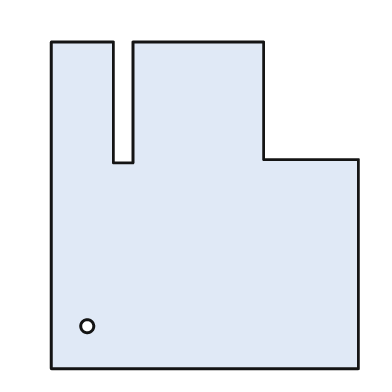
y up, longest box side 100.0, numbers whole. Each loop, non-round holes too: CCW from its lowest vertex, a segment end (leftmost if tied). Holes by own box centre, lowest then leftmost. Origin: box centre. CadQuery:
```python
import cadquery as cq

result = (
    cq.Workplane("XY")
    .moveTo(-47.0, -50.0)
    .lineTo(47.0, -50.0)
    .lineTo(47.0, 14.0)
    .lineTo(18.0, 14.0)
    .lineTo(18.0, 50.0)
    .lineTo(-22.0, 50.0)
    .lineTo(-22.0, 13.0)
    .lineTo(-28.0, 13.0)
    .lineTo(-28.0, 50.0)
    .lineTo(-47.0, 50.0)
    .close()
    .moveTo(-36.0, -37.0)
    .circle(2.0)
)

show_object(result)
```